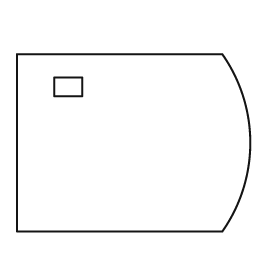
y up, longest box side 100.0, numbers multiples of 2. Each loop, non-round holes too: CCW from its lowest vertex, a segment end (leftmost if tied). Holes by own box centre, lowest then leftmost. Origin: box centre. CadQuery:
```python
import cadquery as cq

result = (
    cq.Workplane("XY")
    .moveTo(-50.0, -38.0)
    .lineTo(38.0, -38.0)
    .threePointArc((50.0, 0.0), (38.0, 38.0))
    .lineTo(-50.0, 38.0)
    .close()
    .moveTo(-34.0, 20.0)
    .lineTo(-22.0, 20.0)
    .lineTo(-22.0, 28.0)
    .lineTo(-34.0, 28.0)
    .close()
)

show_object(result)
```